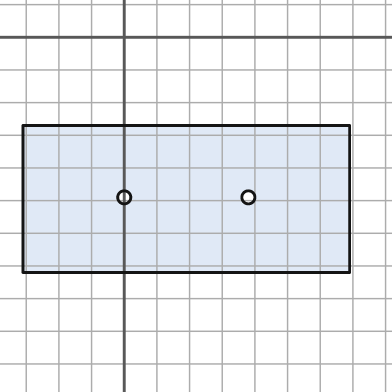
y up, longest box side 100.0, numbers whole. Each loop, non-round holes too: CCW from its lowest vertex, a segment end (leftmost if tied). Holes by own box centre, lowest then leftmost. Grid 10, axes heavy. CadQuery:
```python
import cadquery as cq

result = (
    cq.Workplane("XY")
    .moveTo(-31.0, -72.0)
    .lineTo(69.0, -72.0)
    .lineTo(69.0, -27.0)
    .lineTo(-31.0, -27.0)
    .close()
    .moveTo(0.0, -49.0)
    .circle(2.0)
    .moveTo(38.0, -49.0)
    .circle(2.0)
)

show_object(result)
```